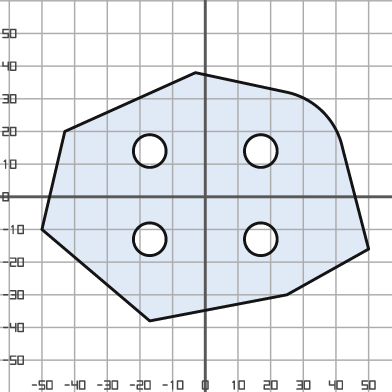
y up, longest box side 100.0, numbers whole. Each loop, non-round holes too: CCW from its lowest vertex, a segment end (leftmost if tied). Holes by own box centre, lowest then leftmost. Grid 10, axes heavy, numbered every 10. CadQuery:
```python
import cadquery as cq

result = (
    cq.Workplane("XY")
    .moveTo(-17.0, -38.0)
    .lineTo(25.0, -30.0)
    .lineTo(50.0, -16.0)
    .lineTo(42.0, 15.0)
    .threePointArc((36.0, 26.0), (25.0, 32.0))
    .lineTo(-3.0, 38.0)
    .lineTo(-43.0, 20.0)
    .lineTo(-50.0, -10.0)
    .close()
    .moveTo(-17.0, -13.0)
    .circle(5.0)
    .moveTo(17.0, -13.0)
    .circle(5.0)
    .moveTo(-17.0, 14.0)
    .circle(5.0)
    .moveTo(17.0, 14.0)
    .circle(5.0)
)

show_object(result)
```